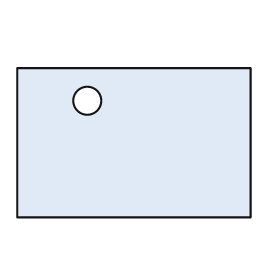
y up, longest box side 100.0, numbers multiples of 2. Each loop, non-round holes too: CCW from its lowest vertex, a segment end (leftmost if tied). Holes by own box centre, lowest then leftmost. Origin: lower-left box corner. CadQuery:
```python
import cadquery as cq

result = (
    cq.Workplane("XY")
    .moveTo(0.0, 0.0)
    .lineTo(100.0, 0.0)
    .lineTo(100.0, 64.0)
    .lineTo(0.0, 64.0)
    .close()
    .moveTo(30.0, 50.0)
    .circle(6.0)
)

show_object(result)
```